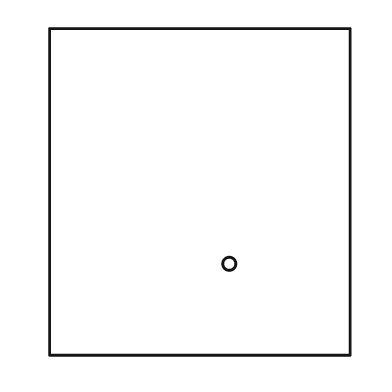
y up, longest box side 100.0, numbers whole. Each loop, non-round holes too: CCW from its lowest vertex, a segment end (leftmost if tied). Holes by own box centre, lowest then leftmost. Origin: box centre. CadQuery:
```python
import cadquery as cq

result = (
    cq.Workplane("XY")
    .moveTo(-46.0, -50.0)
    .lineTo(46.0, -50.0)
    .lineTo(46.0, 50.0)
    .lineTo(-46.0, 50.0)
    .close()
    .moveTo(9.0, -22.0)
    .circle(2.0)
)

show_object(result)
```